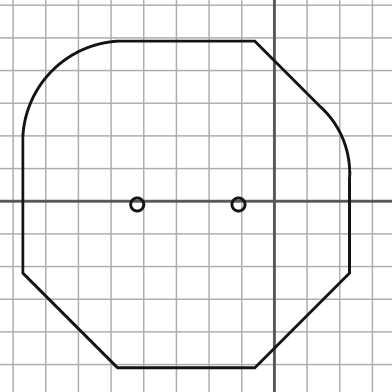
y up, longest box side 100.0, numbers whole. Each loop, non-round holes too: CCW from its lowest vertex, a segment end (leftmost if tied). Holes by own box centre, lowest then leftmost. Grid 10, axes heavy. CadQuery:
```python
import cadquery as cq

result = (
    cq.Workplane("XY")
    .moveTo(-48.0, -51.0)
    .lineTo(-6.0, -51.0)
    .lineTo(23.0, -22.0)
    .lineTo(23.0, 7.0)
    .threePointArc((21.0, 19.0), (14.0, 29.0))
    .lineTo(-6.0, 49.0)
    .lineTo(-48.0, 49.0)
    .threePointArc((-68.0, 40.0), (-77.0, 20.0))
    .lineTo(-77.0, -22.0)
    .close()
    .moveTo(-42.0, -1.0)
    .circle(2.0)
    .moveTo(-11.0, -1.0)
    .circle(2.0)
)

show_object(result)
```